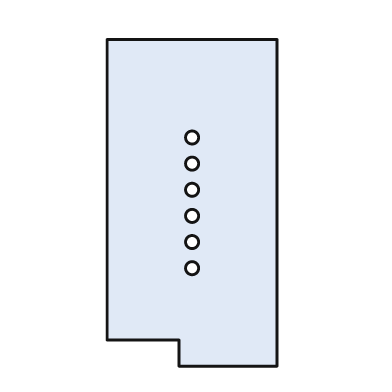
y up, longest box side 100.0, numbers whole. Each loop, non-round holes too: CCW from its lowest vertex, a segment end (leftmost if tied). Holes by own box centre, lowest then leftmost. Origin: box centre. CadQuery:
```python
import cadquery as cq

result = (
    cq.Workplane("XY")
    .moveTo(-4.0, -50.0)
    .lineTo(26.0, -50.0)
    .lineTo(26.0, 50.0)
    .lineTo(-26.0, 50.0)
    .lineTo(-26.0, -42.0)
    .lineTo(-4.0, -42.0)
    .close()
    .moveTo(0.0, -20.0)
    .circle(2.0)
    .moveTo(0.0, -12.0)
    .circle(2.0)
    .moveTo(0.0, -4.0)
    .circle(2.0)
    .moveTo(0.0, 4.0)
    .circle(2.0)
    .moveTo(0.0, 12.0)
    .circle(2.0)
    .moveTo(0.0, 20.0)
    .circle(2.0)
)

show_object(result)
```